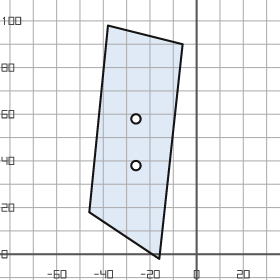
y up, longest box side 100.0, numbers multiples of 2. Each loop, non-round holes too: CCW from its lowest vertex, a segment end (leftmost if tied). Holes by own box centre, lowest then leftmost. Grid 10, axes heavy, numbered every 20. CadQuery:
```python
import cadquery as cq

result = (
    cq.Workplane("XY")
    .moveTo(-16.0, -2.0)
    .lineTo(-6.0, 90.0)
    .lineTo(-38.0, 98.0)
    .lineTo(-46.0, 18.0)
    .close()
    .moveTo(-26.0, 38.0)
    .circle(2.0)
    .moveTo(-26.0, 58.0)
    .circle(2.0)
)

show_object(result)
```